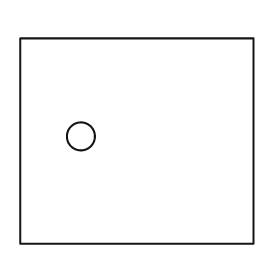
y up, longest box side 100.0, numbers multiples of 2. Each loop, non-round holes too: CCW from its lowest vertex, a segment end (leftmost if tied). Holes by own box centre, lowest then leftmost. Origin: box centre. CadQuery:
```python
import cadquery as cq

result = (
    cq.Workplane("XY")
    .moveTo(-50.0, -44.0)
    .lineTo(50.0, -44.0)
    .lineTo(50.0, 44.0)
    .lineTo(-50.0, 44.0)
    .close()
    .moveTo(-24.0, 2.0)
    .circle(6.0)
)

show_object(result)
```